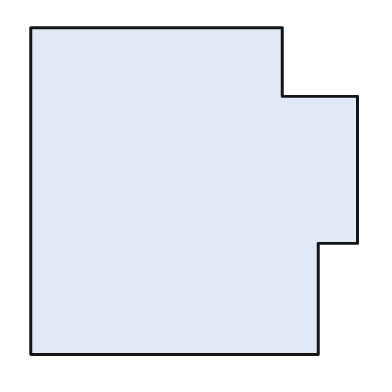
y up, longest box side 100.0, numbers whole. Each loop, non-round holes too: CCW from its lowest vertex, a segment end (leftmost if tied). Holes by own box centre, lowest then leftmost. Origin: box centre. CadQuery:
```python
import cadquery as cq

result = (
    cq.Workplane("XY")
    .moveTo(-50.0, -50.0)
    .lineTo(38.0, -50.0)
    .lineTo(38.0, -16.0)
    .lineTo(50.0, -16.0)
    .lineTo(50.0, 29.0)
    .lineTo(27.0, 29.0)
    .lineTo(27.0, 50.0)
    .lineTo(-50.0, 50.0)
    .close()
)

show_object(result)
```